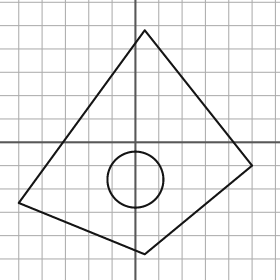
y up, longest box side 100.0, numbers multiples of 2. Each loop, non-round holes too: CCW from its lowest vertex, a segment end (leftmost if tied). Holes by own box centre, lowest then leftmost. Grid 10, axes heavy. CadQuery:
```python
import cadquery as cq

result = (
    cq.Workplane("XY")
    .moveTo(4.0, -48.0)
    .lineTo(50.0, -10.0)
    .lineTo(4.0, 48.0)
    .lineTo(-50.0, -26.0)
    .close()
    .moveTo(0.0, -16.0)
    .circle(12.0)
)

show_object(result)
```